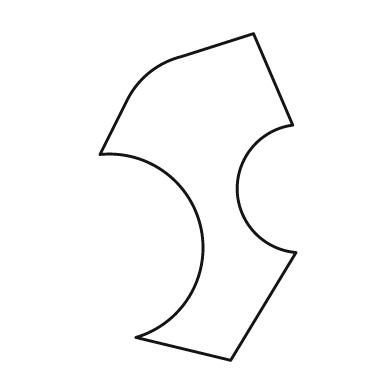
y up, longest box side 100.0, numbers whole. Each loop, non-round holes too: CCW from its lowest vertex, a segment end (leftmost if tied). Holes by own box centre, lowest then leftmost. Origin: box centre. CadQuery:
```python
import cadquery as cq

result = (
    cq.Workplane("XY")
    .moveTo(10.0, -50.0)
    .lineTo(30.0, -17.0)
    .threePointArc((12.0, 2.0), (29.0, 22.0))
    .lineTo(17.0, 50.0)
    .lineTo(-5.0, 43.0)
    .threePointArc((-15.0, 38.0), (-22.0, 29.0))
    .lineTo(-30.0, 13.0)
    .threePointArc((1.0, -10.0), (-19.0, -43.0))
    .close()
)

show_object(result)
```